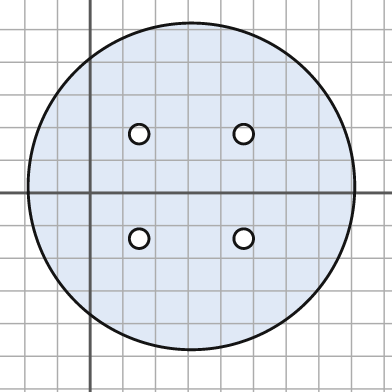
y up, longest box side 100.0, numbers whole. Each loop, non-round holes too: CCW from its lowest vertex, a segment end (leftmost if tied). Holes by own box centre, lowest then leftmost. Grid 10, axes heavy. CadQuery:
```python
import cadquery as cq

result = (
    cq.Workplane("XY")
    .moveTo(31.0, 2.0)
    .circle(50.0)
    .moveTo(15.0, -14.0)
    .circle(3.0)
    .moveTo(47.0, -14.0)
    .circle(3.0)
    .moveTo(15.0, 18.0)
    .circle(3.0)
    .moveTo(47.0, 18.0)
    .circle(3.0)
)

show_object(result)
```